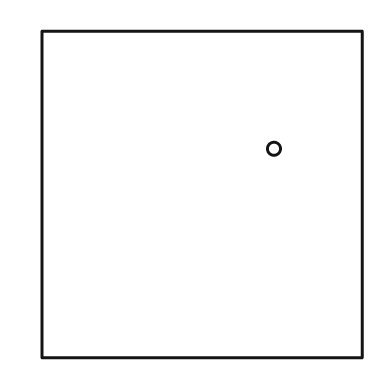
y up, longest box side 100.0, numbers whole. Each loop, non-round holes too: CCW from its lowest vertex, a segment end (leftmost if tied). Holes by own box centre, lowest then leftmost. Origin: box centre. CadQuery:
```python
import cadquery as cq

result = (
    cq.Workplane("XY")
    .moveTo(-49.0, -50.0)
    .lineTo(49.0, -50.0)
    .lineTo(49.0, 50.0)
    .lineTo(-49.0, 50.0)
    .close()
    .moveTo(22.0, 14.0)
    .circle(2.0)
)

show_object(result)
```